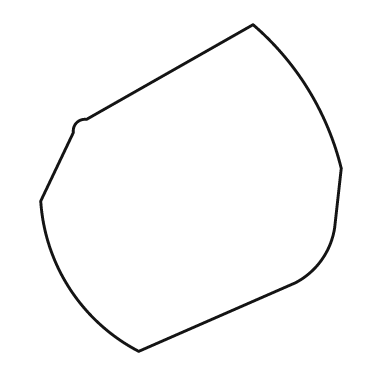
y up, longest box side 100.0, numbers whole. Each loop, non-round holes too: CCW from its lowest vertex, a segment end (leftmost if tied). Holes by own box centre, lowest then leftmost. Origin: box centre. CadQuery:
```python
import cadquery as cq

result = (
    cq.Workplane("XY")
    .moveTo(-16.0, -50.0)
    .lineTo(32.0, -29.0)
    .threePointArc((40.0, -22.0), (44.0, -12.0))
    .lineTo(46.0, 6.0)
    .threePointArc((36.0, 30.0), (19.0, 50.0))
    .lineTo(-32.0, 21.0)
    .threePointArc((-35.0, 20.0), (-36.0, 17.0))
    .lineTo(-46.0, -4.0)
    .threePointArc((-37.0, -31.0), (-16.0, -50.0))
    .close()
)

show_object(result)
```